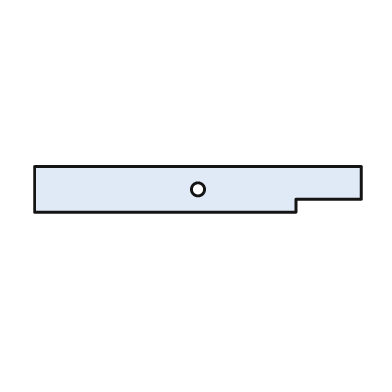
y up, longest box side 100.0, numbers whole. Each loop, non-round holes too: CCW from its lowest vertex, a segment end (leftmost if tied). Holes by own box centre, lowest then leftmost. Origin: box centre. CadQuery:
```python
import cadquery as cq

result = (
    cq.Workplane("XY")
    .moveTo(-50.0, -7.0)
    .lineTo(30.0, -7.0)
    .lineTo(30.0, -3.0)
    .lineTo(50.0, -3.0)
    .lineTo(50.0, 7.0)
    .lineTo(-50.0, 7.0)
    .close()
    .moveTo(0.0, 0.0)
    .circle(2.0)
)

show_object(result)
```